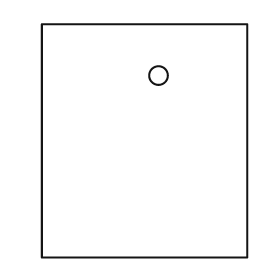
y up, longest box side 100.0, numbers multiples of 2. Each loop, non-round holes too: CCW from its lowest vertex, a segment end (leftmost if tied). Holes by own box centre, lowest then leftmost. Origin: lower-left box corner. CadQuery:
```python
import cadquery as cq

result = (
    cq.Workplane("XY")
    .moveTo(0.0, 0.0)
    .lineTo(88.0, 0.0)
    .lineTo(88.0, 100.0)
    .lineTo(0.0, 100.0)
    .close()
    .moveTo(50.0, 78.0)
    .circle(4.0)
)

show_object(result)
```